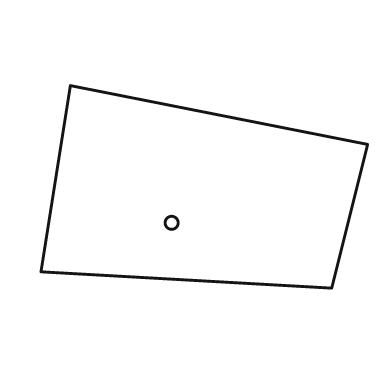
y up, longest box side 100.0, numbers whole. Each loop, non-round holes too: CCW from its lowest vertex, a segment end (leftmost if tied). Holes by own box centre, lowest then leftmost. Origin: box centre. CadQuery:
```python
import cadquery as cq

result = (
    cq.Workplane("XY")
    .moveTo(39.0, -31.0)
    .lineTo(50.0, 13.0)
    .lineTo(-41.0, 31.0)
    .lineTo(-50.0, -26.0)
    .close()
    .moveTo(-10.0, -11.0)
    .circle(2.0)
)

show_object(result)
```